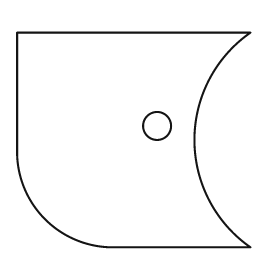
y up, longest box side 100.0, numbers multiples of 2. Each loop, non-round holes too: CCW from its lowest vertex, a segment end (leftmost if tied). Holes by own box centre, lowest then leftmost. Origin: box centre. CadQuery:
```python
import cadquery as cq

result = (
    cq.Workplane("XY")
    .moveTo(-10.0, -46.0)
    .lineTo(50.0, -46.0)
    .threePointArc((26.0, 0.0), (50.0, 46.0))
    .lineTo(-50.0, 46.0)
    .lineTo(-50.0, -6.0)
    .threePointArc((-38.0, -34.0), (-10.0, -46.0))
    .close()
    .moveTo(10.0, 6.0)
    .circle(6.0)
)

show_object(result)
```